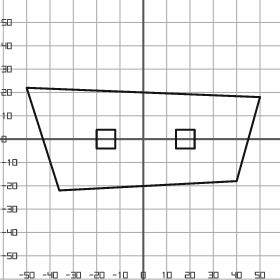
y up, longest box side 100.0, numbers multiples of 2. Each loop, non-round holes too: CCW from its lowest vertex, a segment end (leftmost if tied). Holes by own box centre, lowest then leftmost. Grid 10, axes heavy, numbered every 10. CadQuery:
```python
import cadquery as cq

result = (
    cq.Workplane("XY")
    .moveTo(-36.0, -22.0)
    .lineTo(40.0, -18.0)
    .lineTo(50.0, 18.0)
    .lineTo(-50.0, 22.0)
    .close()
    .moveTo(-20.0, -4.0)
    .lineTo(-12.0, -4.0)
    .lineTo(-12.0, 4.0)
    .lineTo(-20.0, 4.0)
    .close()
    .moveTo(14.0, -4.0)
    .lineTo(22.0, -4.0)
    .lineTo(22.0, 4.0)
    .lineTo(14.0, 4.0)
    .close()
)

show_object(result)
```